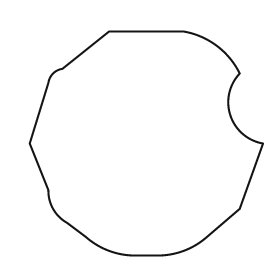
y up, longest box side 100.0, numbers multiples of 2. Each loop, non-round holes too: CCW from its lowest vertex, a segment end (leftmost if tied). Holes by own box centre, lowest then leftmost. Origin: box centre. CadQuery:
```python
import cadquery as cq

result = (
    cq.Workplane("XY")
    .moveTo(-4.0, -48.0)
    .lineTo(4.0, -48.0)
    .threePointArc((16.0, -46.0), (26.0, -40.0))
    .lineTo(40.0, -28.0)
    .lineTo(50.0, 0.0)
    .threePointArc((36.0, 12.0), (40.0, 30.0))
    .threePointArc((30.0, 42.0), (16.0, 48.0))
    .lineTo(-16.0, 48.0)
    .lineTo(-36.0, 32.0)
    .threePointArc((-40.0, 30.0), (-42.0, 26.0))
    .lineTo(-50.0, 0.0)
    .lineTo(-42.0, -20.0)
    .threePointArc((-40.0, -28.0), (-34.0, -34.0))
    .lineTo(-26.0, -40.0)
    .threePointArc((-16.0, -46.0), (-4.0, -48.0))
    .close()
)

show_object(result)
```